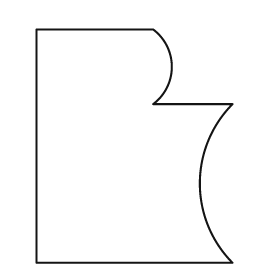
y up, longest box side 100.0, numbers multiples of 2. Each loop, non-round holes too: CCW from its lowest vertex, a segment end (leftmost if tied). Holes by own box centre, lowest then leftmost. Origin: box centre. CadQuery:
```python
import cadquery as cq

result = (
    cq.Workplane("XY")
    .moveTo(-42.0, -50.0)
    .lineTo(42.0, -50.0)
    .threePointArc((28.0, -16.0), (42.0, 18.0))
    .lineTo(8.0, 18.0)
    .threePointArc((16.0, 34.0), (8.0, 50.0))
    .lineTo(-42.0, 50.0)
    .close()
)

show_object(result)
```